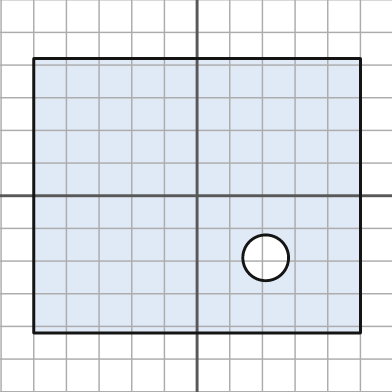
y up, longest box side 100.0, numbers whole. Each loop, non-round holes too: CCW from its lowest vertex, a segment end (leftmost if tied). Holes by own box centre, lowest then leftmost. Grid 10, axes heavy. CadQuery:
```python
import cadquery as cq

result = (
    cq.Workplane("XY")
    .moveTo(-50.0, -42.0)
    .lineTo(50.0, -42.0)
    .lineTo(50.0, 42.0)
    .lineTo(-50.0, 42.0)
    .close()
    .moveTo(21.0, -19.0)
    .circle(7.0)
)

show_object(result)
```